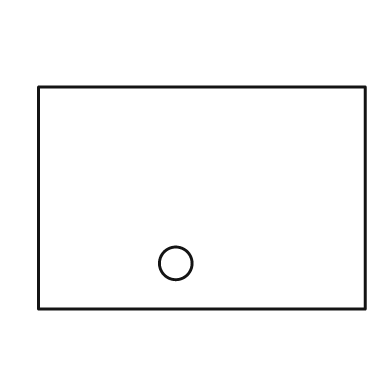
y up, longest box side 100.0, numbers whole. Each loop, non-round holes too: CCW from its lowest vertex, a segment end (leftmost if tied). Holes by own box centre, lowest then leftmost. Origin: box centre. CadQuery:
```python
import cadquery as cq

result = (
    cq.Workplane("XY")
    .moveTo(-50.0, -34.0)
    .lineTo(50.0, -34.0)
    .lineTo(50.0, 34.0)
    .lineTo(-50.0, 34.0)
    .close()
    .moveTo(-8.0, -20.0)
    .circle(5.0)
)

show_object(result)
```